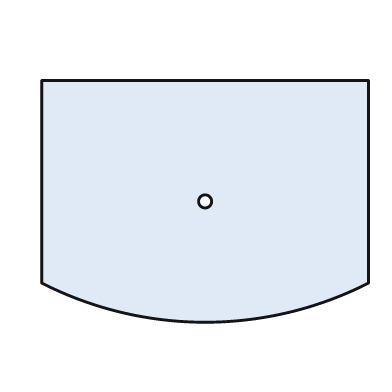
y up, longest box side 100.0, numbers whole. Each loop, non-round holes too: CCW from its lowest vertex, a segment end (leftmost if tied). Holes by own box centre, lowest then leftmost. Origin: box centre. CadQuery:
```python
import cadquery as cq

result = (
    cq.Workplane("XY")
    .moveTo(-50.0, -25.0)
    .threePointArc((0.0, -37.0), (50.0, -25.0))
    .lineTo(50.0, 37.0)
    .lineTo(-50.0, 37.0)
    .close()
    .moveTo(0.0, 0.0)
    .circle(2.0)
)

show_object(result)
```